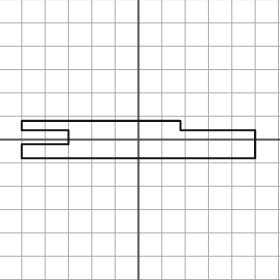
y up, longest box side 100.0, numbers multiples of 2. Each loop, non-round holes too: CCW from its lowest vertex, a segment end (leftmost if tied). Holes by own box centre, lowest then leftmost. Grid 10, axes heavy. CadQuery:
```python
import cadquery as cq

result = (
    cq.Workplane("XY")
    .moveTo(-50.0, -8.0)
    .lineTo(50.0, -8.0)
    .lineTo(50.0, 4.0)
    .lineTo(18.0, 4.0)
    .lineTo(18.0, 8.0)
    .lineTo(-50.0, 8.0)
    .lineTo(-50.0, 4.0)
    .lineTo(-30.0, 4.0)
    .lineTo(-30.0, -2.0)
    .lineTo(-50.0, -2.0)
    .close()
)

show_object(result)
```